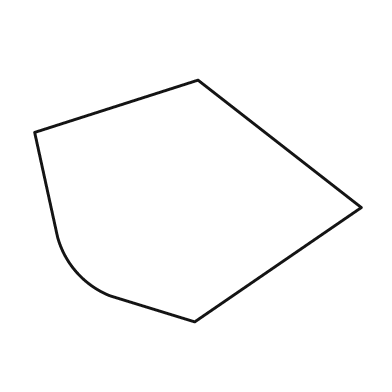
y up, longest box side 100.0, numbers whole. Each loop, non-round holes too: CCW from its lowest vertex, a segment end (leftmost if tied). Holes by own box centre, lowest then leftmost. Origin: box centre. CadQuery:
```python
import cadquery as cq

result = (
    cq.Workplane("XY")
    .moveTo(-1.0, -37.0)
    .lineTo(50.0, -2.0)
    .lineTo(0.0, 37.0)
    .lineTo(-50.0, 21.0)
    .lineTo(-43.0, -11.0)
    .threePointArc((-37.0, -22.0), (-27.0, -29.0))
    .close()
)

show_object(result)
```